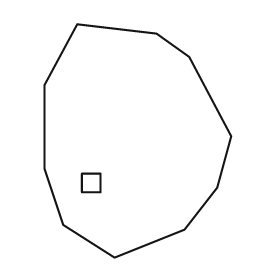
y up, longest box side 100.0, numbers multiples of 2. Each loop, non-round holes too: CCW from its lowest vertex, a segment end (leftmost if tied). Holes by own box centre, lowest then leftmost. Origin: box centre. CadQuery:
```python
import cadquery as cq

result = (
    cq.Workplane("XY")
    .moveTo(-10.0, -50.0)
    .lineTo(20.0, -38.0)
    .lineTo(34.0, -20.0)
    .lineTo(40.0, 2.0)
    .lineTo(22.0, 36.0)
    .lineTo(8.0, 46.0)
    .lineTo(-26.0, 50.0)
    .lineTo(-40.0, 24.0)
    .lineTo(-40.0, -12.0)
    .lineTo(-32.0, -36.0)
    .close()
    .moveTo(-24.0, -22.0)
    .lineTo(-16.0, -22.0)
    .lineTo(-16.0, -14.0)
    .lineTo(-24.0, -14.0)
    .close()
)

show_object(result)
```